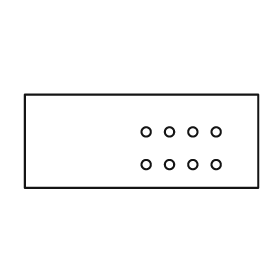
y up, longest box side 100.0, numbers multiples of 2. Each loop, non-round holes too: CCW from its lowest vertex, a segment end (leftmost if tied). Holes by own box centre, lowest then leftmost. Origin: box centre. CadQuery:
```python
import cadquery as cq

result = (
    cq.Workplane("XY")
    .moveTo(-50.0, -20.0)
    .lineTo(50.0, -20.0)
    .lineTo(50.0, 20.0)
    .lineTo(-50.0, 20.0)
    .close()
    .moveTo(2.0, -10.0)
    .circle(2.0)
    .moveTo(12.0, -10.0)
    .circle(2.0)
    .moveTo(22.0, -10.0)
    .circle(2.0)
    .moveTo(32.0, -10.0)
    .circle(2.0)
    .moveTo(2.0, 4.0)
    .circle(2.0)
    .moveTo(12.0, 4.0)
    .circle(2.0)
    .moveTo(22.0, 4.0)
    .circle(2.0)
    .moveTo(32.0, 4.0)
    .circle(2.0)
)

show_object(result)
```